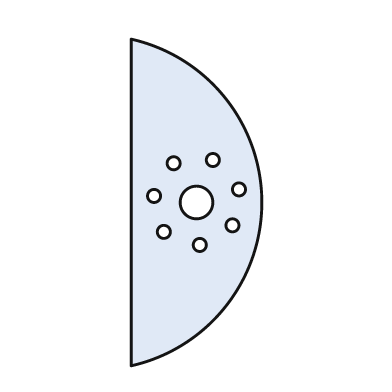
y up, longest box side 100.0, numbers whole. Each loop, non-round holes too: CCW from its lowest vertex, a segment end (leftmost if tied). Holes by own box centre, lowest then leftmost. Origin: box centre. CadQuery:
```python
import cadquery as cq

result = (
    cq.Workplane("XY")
    .moveTo(-20.0, -50.0)
    .threePointArc((20.0, 0.0), (-20.0, 50.0))
    .close()
    .moveTo(1.0, -13.0)
    .circle(2.0)
    .moveTo(-10.0, -9.0)
    .circle(2.0)
    .moveTo(11.0, -7.0)
    .circle(2.0)
    .moveTo(0.0, 0.0)
    .circle(5.0)
    .moveTo(-13.0, 2.0)
    .circle(2.0)
    .moveTo(13.0, 4.0)
    .circle(2.0)
    .moveTo(-7.0, 12.0)
    .circle(2.0)
    .moveTo(5.0, 13.0)
    .circle(2.0)
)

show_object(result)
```